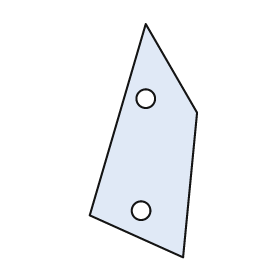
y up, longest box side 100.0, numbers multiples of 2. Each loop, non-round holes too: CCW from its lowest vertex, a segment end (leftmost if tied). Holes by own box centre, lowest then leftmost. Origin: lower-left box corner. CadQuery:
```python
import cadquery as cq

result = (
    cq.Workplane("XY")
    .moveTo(40.0, 0.0)
    .lineTo(46.0, 62.0)
    .lineTo(24.0, 100.0)
    .lineTo(0.0, 18.0)
    .close()
    .moveTo(22.0, 20.0)
    .circle(4.0)
    .moveTo(24.0, 68.0)
    .circle(4.0)
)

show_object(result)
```